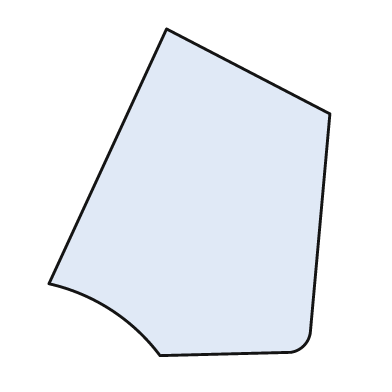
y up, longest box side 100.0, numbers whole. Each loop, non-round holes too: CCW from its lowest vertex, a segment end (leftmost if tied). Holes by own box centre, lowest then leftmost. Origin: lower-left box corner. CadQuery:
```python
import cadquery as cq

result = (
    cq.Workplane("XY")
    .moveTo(34.0, 0.0)
    .lineTo(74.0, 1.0)
    .threePointArc((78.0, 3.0), (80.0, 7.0))
    .lineTo(86.0, 74.0)
    .lineTo(36.0, 100.0)
    .lineTo(0.0, 22.0)
    .threePointArc((19.0, 14.0), (34.0, 0.0))
    .close()
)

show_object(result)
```